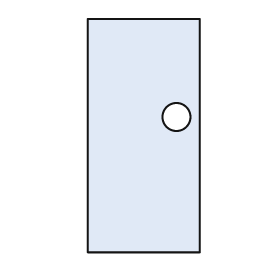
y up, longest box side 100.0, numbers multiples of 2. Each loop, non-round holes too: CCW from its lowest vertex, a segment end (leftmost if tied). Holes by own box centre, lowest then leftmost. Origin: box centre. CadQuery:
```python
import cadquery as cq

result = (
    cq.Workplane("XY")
    .moveTo(-24.0, -50.0)
    .lineTo(24.0, -50.0)
    .lineTo(24.0, 50.0)
    .lineTo(-24.0, 50.0)
    .close()
    .moveTo(14.0, 8.0)
    .circle(6.0)
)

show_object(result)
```